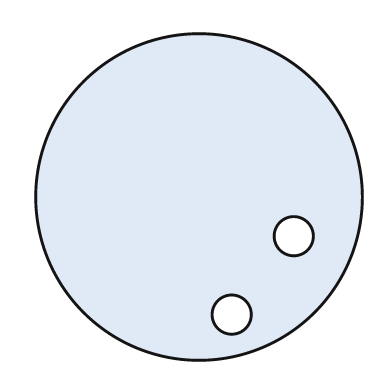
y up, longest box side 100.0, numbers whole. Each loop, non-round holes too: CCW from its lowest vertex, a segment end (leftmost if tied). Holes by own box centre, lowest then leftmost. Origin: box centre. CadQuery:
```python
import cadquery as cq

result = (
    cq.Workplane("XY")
    .moveTo(0.0, 0.0)
    .circle(50.0)
    .moveTo(10.0, -36.0)
    .circle(6.0)
    .moveTo(29.0, -12.0)
    .circle(6.0)
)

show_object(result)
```